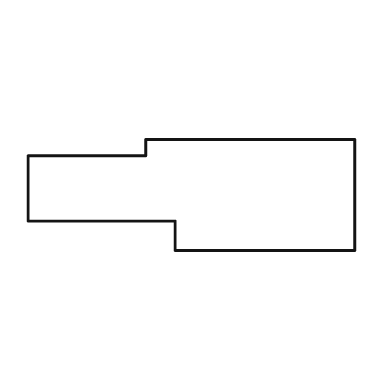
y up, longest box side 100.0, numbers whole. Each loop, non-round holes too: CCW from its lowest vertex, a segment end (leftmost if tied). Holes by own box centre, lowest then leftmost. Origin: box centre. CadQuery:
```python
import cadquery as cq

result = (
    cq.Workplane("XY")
    .moveTo(-5.0, -17.0)
    .lineTo(50.0, -17.0)
    .lineTo(50.0, 17.0)
    .lineTo(-14.0, 17.0)
    .lineTo(-14.0, 12.0)
    .lineTo(-50.0, 12.0)
    .lineTo(-50.0, -8.0)
    .lineTo(-5.0, -8.0)
    .close()
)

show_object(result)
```